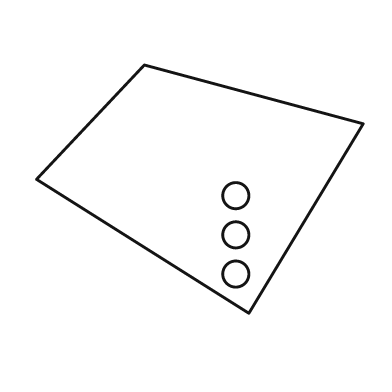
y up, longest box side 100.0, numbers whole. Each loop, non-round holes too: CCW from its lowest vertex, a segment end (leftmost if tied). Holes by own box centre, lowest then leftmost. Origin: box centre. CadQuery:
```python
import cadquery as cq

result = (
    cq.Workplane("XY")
    .moveTo(15.0, -38.0)
    .lineTo(50.0, 20.0)
    .lineTo(-17.0, 38.0)
    .lineTo(-50.0, 3.0)
    .close()
    .moveTo(11.0, -26.0)
    .circle(4.0)
    .moveTo(11.0, -14.0)
    .circle(4.0)
    .moveTo(11.0, -2.0)
    .circle(4.0)
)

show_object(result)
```